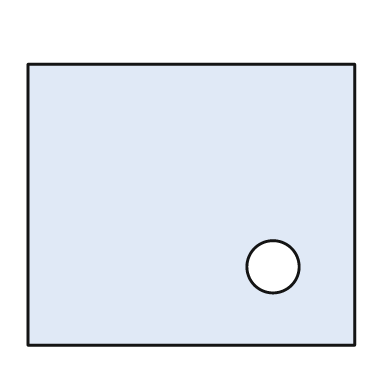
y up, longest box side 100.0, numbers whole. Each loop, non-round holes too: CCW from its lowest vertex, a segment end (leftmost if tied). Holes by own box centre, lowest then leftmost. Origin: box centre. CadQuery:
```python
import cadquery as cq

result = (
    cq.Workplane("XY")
    .moveTo(-50.0, -43.0)
    .lineTo(50.0, -43.0)
    .lineTo(50.0, 43.0)
    .lineTo(-50.0, 43.0)
    .close()
    .moveTo(25.0, -19.0)
    .circle(8.0)
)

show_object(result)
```